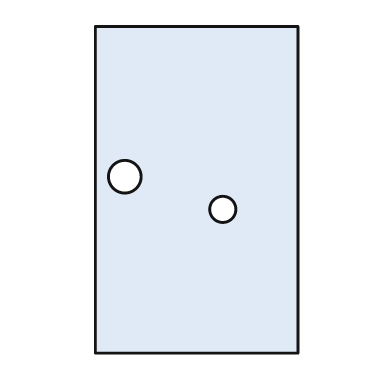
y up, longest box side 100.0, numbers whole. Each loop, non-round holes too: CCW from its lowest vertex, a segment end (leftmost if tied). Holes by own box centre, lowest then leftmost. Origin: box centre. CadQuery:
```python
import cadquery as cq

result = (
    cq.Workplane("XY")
    .moveTo(-31.0, -50.0)
    .lineTo(31.0, -50.0)
    .lineTo(31.0, 50.0)
    .lineTo(-31.0, 50.0)
    .close()
    .moveTo(8.0, -6.0)
    .circle(4.0)
    .moveTo(-22.0, 4.0)
    .circle(5.0)
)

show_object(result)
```